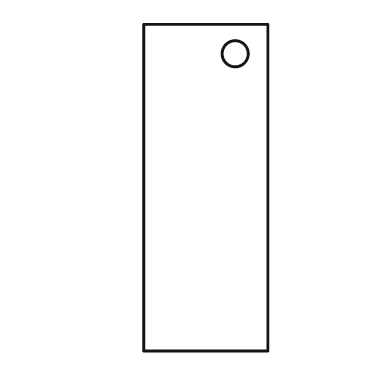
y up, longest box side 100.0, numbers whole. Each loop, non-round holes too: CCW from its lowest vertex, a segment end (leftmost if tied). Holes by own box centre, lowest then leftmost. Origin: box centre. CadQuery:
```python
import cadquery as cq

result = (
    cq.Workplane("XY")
    .moveTo(-19.0, -50.0)
    .lineTo(19.0, -50.0)
    .lineTo(19.0, 50.0)
    .lineTo(-19.0, 50.0)
    .close()
    .moveTo(9.0, 41.0)
    .circle(4.0)
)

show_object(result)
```